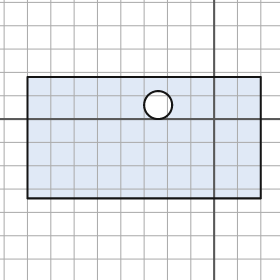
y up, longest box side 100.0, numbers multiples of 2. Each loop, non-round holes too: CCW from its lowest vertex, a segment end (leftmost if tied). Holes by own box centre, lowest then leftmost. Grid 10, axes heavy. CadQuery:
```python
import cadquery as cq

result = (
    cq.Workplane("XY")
    .moveTo(-80.0, -34.0)
    .lineTo(20.0, -34.0)
    .lineTo(20.0, 18.0)
    .lineTo(-80.0, 18.0)
    .close()
    .moveTo(-24.0, 6.0)
    .circle(6.0)
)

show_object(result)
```